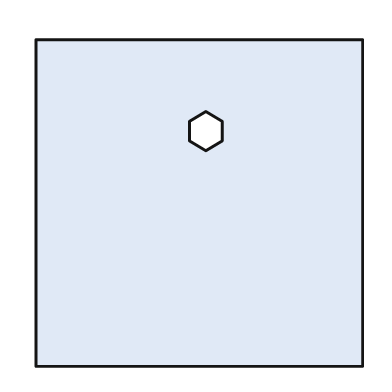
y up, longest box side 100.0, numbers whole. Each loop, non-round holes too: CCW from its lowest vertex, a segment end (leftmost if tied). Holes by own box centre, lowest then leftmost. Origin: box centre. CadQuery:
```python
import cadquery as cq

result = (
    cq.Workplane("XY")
    .moveTo(-50.0, -50.0)
    .lineTo(50.0, -50.0)
    .lineTo(50.0, 50.0)
    .lineTo(-50.0, 50.0)
    .close()
    .moveTo(2.0, 16.0)
    .lineTo(7.0, 19.0)
    .lineTo(7.0, 25.0)
    .lineTo(2.0, 28.0)
    .lineTo(-3.0, 25.0)
    .lineTo(-3.0, 19.0)
    .close()
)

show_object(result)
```